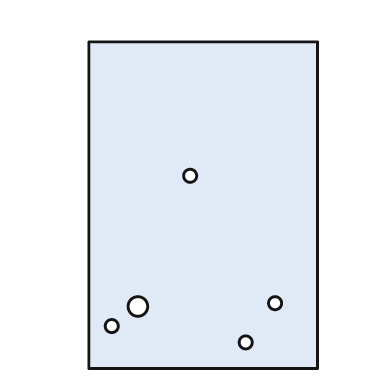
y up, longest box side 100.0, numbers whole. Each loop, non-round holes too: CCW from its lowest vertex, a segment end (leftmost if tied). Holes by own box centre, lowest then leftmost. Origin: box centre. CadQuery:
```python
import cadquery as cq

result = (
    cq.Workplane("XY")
    .moveTo(-35.0, -50.0)
    .lineTo(35.0, -50.0)
    .lineTo(35.0, 50.0)
    .lineTo(-35.0, 50.0)
    .close()
    .moveTo(13.0, -42.0)
    .circle(2.0)
    .moveTo(-28.0, -37.0)
    .circle(2.0)
    .moveTo(-20.0, -31.0)
    .circle(3.0)
    .moveTo(22.0, -30.0)
    .circle(2.0)
    .moveTo(-4.0, 9.0)
    .circle(2.0)
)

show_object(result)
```